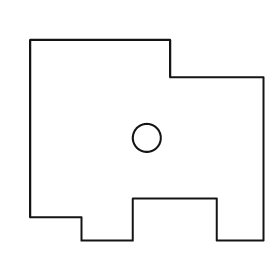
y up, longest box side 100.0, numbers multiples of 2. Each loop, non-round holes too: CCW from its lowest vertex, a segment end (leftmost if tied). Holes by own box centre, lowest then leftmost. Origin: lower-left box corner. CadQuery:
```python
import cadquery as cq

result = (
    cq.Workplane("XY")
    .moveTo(22.0, 0.0)
    .lineTo(44.0, 0.0)
    .lineTo(44.0, 18.0)
    .lineTo(80.0, 18.0)
    .lineTo(80.0, 0.0)
    .lineTo(100.0, 0.0)
    .lineTo(100.0, 70.0)
    .lineTo(60.0, 70.0)
    .lineTo(60.0, 86.0)
    .lineTo(0.0, 86.0)
    .lineTo(0.0, 10.0)
    .lineTo(22.0, 10.0)
    .close()
    .moveTo(50.0, 44.0)
    .circle(6.0)
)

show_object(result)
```